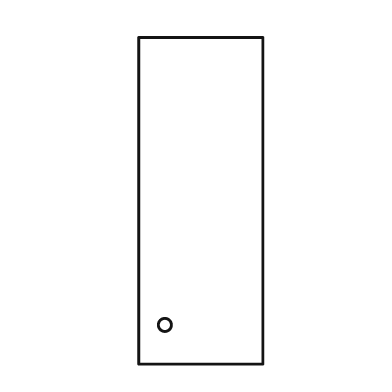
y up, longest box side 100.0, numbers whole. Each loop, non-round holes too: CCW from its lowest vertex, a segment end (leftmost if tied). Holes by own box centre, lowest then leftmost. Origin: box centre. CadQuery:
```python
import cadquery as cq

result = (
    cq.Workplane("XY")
    .moveTo(-19.0, -50.0)
    .lineTo(19.0, -50.0)
    .lineTo(19.0, 50.0)
    .lineTo(-19.0, 50.0)
    .close()
    .moveTo(-11.0, -38.0)
    .circle(2.0)
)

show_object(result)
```